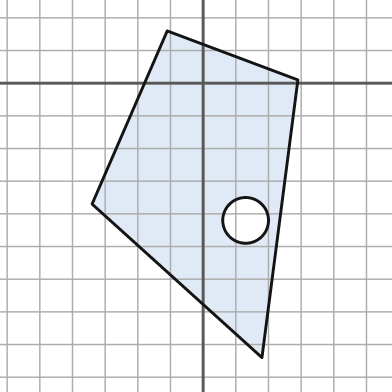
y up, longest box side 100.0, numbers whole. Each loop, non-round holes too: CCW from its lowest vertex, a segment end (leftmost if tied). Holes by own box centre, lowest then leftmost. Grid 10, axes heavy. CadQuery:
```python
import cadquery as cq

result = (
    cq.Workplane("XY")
    .moveTo(18.0, -84.0)
    .lineTo(29.0, 1.0)
    .lineTo(-11.0, 16.0)
    .lineTo(-34.0, -37.0)
    .close()
    .moveTo(13.0, -42.0)
    .circle(7.0)
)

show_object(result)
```